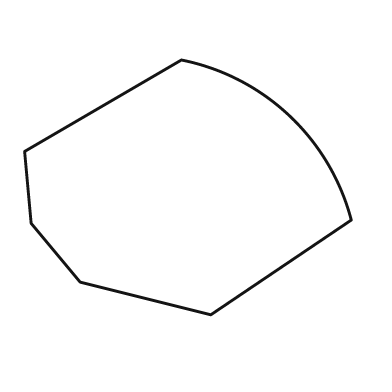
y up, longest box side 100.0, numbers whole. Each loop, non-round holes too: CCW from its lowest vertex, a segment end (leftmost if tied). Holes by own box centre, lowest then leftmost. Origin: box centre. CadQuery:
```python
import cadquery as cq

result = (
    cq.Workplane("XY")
    .moveTo(7.0, -39.0)
    .lineTo(50.0, -10.0)
    .threePointArc((31.0, 22.0), (-2.0, 39.0))
    .lineTo(-50.0, 11.0)
    .lineTo(-48.0, -11.0)
    .lineTo(-33.0, -29.0)
    .close()
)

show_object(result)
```